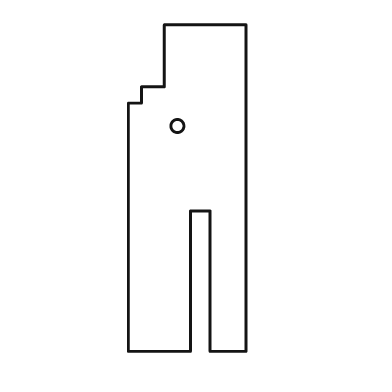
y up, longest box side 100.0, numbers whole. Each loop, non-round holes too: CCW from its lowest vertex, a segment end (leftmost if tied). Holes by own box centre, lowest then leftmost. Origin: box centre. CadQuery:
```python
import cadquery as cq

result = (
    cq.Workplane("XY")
    .moveTo(-18.0, -50.0)
    .lineTo(1.0, -50.0)
    .lineTo(1.0, -7.0)
    .lineTo(7.0, -7.0)
    .lineTo(7.0, -50.0)
    .lineTo(18.0, -50.0)
    .lineTo(18.0, 50.0)
    .lineTo(-7.0, 50.0)
    .lineTo(-7.0, 31.0)
    .lineTo(-14.0, 31.0)
    .lineTo(-14.0, 26.0)
    .lineTo(-18.0, 26.0)
    .close()
    .moveTo(-3.0, 19.0)
    .circle(2.0)
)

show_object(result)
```